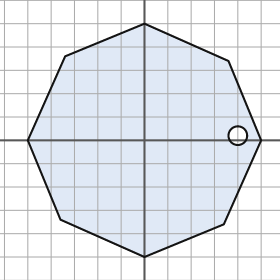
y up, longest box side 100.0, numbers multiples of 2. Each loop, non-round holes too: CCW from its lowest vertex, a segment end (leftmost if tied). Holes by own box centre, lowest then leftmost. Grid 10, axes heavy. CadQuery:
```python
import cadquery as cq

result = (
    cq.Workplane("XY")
    .moveTo(0.0, -50.0)
    .lineTo(34.0, -36.0)
    .lineTo(50.0, 0.0)
    .lineTo(36.0, 34.0)
    .lineTo(0.0, 50.0)
    .lineTo(-34.0, 36.0)
    .lineTo(-50.0, 0.0)
    .lineTo(-36.0, -34.0)
    .close()
    .moveTo(40.0, 2.0)
    .circle(4.0)
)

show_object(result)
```